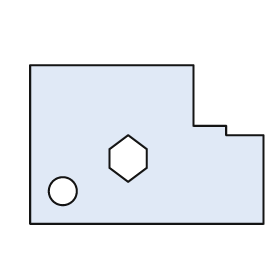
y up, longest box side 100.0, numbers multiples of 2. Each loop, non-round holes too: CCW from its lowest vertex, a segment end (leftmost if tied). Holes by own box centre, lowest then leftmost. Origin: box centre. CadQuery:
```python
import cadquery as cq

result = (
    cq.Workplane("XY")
    .moveTo(-50.0, -34.0)
    .lineTo(50.0, -34.0)
    .lineTo(50.0, 4.0)
    .lineTo(34.0, 4.0)
    .lineTo(34.0, 8.0)
    .lineTo(20.0, 8.0)
    .lineTo(20.0, 34.0)
    .lineTo(-50.0, 34.0)
    .close()
    .moveTo(-36.0, -20.0)
    .circle(6.0)
    .moveTo(-8.0, -16.0)
    .lineTo(0.0, -10.0)
    .lineTo(0.0, -2.0)
    .lineTo(-8.0, 4.0)
    .lineTo(-16.0, -2.0)
    .lineTo(-16.0, -10.0)
    .close()
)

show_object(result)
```